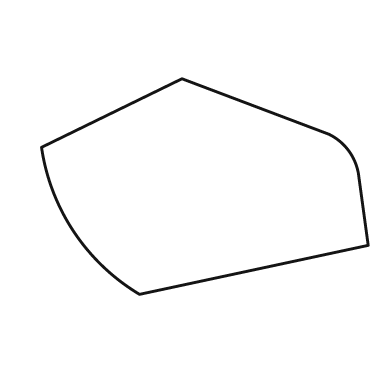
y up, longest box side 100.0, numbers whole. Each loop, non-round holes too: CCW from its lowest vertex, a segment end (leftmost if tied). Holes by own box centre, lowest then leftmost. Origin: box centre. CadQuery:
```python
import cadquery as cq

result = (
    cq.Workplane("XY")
    .moveTo(-20.0, -33.0)
    .lineTo(50.0, -18.0)
    .lineTo(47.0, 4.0)
    .threePointArc((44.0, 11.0), (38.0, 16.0))
    .lineTo(-7.0, 33.0)
    .lineTo(-50.0, 12.0)
    .threePointArc((-40.0, -14.0), (-20.0, -33.0))
    .close()
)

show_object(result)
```